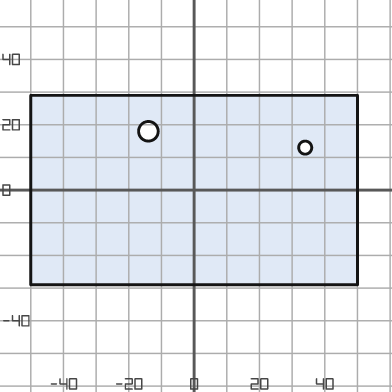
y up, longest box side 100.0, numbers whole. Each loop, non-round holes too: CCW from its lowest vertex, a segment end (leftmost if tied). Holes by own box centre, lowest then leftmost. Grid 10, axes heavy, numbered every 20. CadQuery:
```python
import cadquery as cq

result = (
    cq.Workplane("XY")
    .moveTo(-50.0, -29.0)
    .lineTo(50.0, -29.0)
    .lineTo(50.0, 29.0)
    .lineTo(-50.0, 29.0)
    .close()
    .moveTo(34.0, 13.0)
    .circle(2.0)
    .moveTo(-14.0, 18.0)
    .circle(3.0)
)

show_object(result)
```